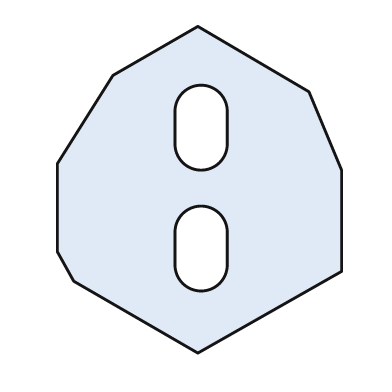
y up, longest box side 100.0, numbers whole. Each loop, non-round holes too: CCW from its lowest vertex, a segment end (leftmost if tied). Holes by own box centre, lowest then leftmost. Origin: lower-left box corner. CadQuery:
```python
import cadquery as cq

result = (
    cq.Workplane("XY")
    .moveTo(43.0, 0.0)
    .lineTo(87.0, 25.0)
    .lineTo(87.0, 56.0)
    .lineTo(77.0, 80.0)
    .lineTo(43.0, 100.0)
    .lineTo(17.0, 85.0)
    .lineTo(0.0, 58.0)
    .lineTo(0.0, 31.0)
    .lineTo(5.0, 22.0)
    .close()
    .moveTo(36.0, 27.0)
    .threePointArc((44.0, 19.0), (52.0, 27.0))
    .lineTo(52.0, 37.0)
    .threePointArc((44.0, 45.0), (36.0, 37.0))
    .close()
    .moveTo(36.0, 64.0)
    .threePointArc((44.0, 56.0), (52.0, 64.0))
    .lineTo(52.0, 74.0)
    .threePointArc((44.0, 82.0), (36.0, 74.0))
    .close()
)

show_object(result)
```